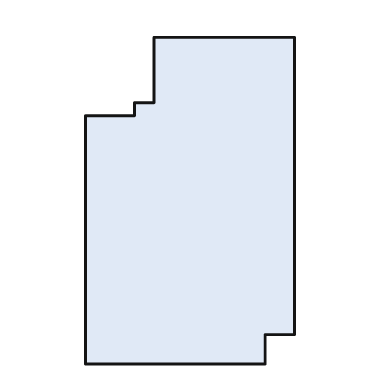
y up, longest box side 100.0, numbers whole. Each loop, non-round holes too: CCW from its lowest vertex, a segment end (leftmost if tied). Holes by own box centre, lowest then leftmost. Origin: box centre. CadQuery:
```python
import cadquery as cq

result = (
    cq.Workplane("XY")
    .moveTo(-32.0, -50.0)
    .lineTo(23.0, -50.0)
    .lineTo(23.0, -41.0)
    .lineTo(32.0, -41.0)
    .lineTo(32.0, 50.0)
    .lineTo(-11.0, 50.0)
    .lineTo(-11.0, 30.0)
    .lineTo(-17.0, 30.0)
    .lineTo(-17.0, 26.0)
    .lineTo(-32.0, 26.0)
    .close()
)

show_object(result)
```